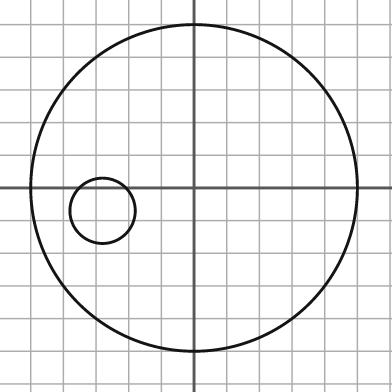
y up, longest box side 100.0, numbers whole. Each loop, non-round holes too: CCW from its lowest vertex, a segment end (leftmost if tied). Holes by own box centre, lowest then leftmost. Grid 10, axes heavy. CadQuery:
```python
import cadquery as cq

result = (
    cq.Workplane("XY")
    .moveTo(0.0, 0.0)
    .circle(50.0)
    .moveTo(-28.0, -7.0)
    .circle(10.0)
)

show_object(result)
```